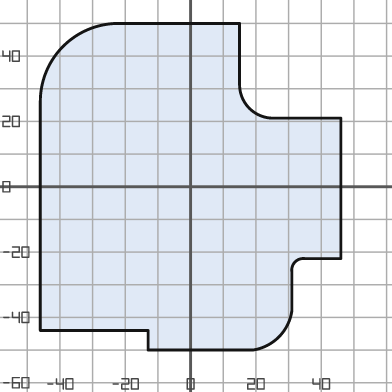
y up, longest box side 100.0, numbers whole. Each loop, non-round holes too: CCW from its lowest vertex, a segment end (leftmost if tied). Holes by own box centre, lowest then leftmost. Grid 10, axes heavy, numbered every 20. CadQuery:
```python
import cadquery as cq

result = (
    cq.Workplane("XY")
    .moveTo(-13.0, -50.0)
    .lineTo(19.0, -50.0)
    .threePointArc((27.0, -46.0), (31.0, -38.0))
    .lineTo(31.0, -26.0)
    .threePointArc((32.0, -23.0), (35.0, -22.0))
    .lineTo(46.0, -22.0)
    .lineTo(46.0, 21.0)
    .lineTo(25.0, 21.0)
    .threePointArc((18.0, 24.0), (15.0, 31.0))
    .lineTo(15.0, 50.0)
    .lineTo(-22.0, 50.0)
    .threePointArc((-39.0, 43.0), (-46.0, 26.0))
    .lineTo(-46.0, -44.0)
    .lineTo(-13.0, -44.0)
    .close()
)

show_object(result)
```